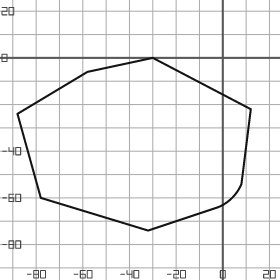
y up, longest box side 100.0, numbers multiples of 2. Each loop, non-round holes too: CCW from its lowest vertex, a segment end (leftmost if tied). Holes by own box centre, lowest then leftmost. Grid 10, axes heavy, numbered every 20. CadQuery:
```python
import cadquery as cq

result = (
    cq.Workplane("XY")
    .moveTo(-32.0, -74.0)
    .lineTo(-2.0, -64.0)
    .threePointArc((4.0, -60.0), (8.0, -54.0))
    .lineTo(12.0, -22.0)
    .lineTo(-30.0, 0.0)
    .lineTo(-58.0, -6.0)
    .lineTo(-88.0, -24.0)
    .lineTo(-78.0, -60.0)
    .close()
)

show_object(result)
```